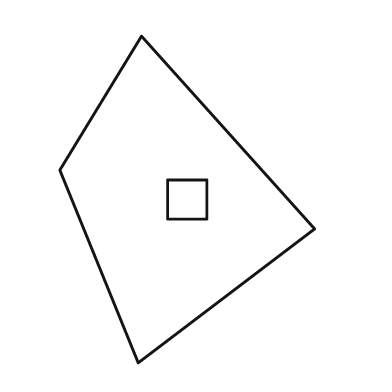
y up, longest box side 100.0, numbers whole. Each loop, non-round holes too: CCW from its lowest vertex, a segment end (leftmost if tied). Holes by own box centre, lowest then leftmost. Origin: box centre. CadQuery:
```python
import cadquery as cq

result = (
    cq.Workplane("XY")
    .moveTo(-15.0, -50.0)
    .lineTo(39.0, -9.0)
    .lineTo(-14.0, 50.0)
    .lineTo(-39.0, 9.0)
    .close()
    .moveTo(-6.0, -6.0)
    .lineTo(6.0, -6.0)
    .lineTo(6.0, 6.0)
    .lineTo(-6.0, 6.0)
    .close()
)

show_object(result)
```